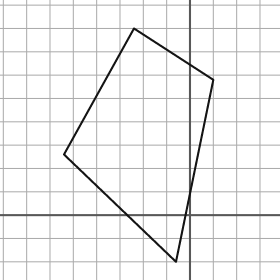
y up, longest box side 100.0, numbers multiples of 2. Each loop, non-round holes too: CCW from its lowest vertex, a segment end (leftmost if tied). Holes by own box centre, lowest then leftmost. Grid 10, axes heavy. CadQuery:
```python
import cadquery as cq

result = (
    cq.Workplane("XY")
    .moveTo(-6.0, -20.0)
    .lineTo(10.0, 58.0)
    .lineTo(-24.0, 80.0)
    .lineTo(-54.0, 26.0)
    .close()
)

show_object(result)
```